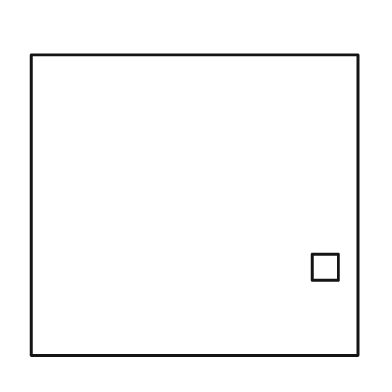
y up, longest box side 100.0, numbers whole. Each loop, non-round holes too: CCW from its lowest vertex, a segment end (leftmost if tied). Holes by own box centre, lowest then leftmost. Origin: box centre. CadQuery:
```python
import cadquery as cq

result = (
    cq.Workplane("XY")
    .moveTo(-50.0, -46.0)
    .lineTo(50.0, -46.0)
    .lineTo(50.0, 46.0)
    .lineTo(-50.0, 46.0)
    .close()
    .moveTo(36.0, -23.0)
    .lineTo(44.0, -23.0)
    .lineTo(44.0, -15.0)
    .lineTo(36.0, -15.0)
    .close()
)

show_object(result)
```